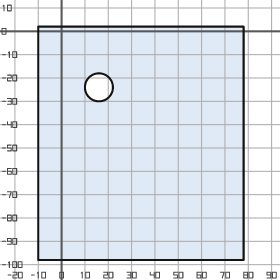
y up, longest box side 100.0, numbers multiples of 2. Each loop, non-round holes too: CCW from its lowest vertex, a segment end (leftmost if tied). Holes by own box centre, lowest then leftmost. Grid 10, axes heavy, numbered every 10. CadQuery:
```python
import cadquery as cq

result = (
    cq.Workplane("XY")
    .moveTo(-10.0, -98.0)
    .lineTo(78.0, -98.0)
    .lineTo(78.0, 2.0)
    .lineTo(-10.0, 2.0)
    .close()
    .moveTo(16.0, -24.0)
    .circle(6.0)
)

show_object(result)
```